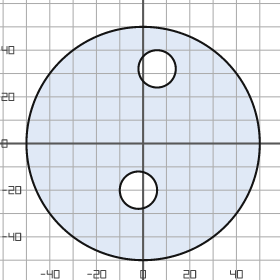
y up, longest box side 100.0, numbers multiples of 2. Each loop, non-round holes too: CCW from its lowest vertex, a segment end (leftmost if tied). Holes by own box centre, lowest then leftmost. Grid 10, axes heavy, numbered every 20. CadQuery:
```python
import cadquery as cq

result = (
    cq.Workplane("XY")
    .moveTo(0.0, 0.0)
    .circle(50.0)
    .moveTo(-2.0, -20.0)
    .circle(8.0)
    .moveTo(6.0, 32.0)
    .circle(8.0)
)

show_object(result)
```